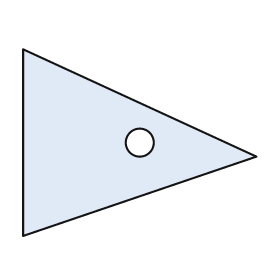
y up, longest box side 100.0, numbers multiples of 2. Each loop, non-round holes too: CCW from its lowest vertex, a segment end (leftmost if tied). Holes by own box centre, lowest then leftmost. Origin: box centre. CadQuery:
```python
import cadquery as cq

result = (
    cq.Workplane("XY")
    .moveTo(-50.0, -40.0)
    .lineTo(50.0, -6.0)
    .lineTo(-50.0, 40.0)
    .close()
    .moveTo(0.0, 0.0)
    .circle(6.0)
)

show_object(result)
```